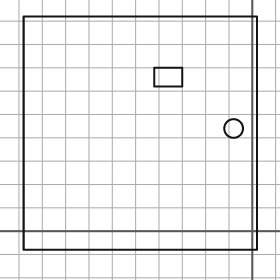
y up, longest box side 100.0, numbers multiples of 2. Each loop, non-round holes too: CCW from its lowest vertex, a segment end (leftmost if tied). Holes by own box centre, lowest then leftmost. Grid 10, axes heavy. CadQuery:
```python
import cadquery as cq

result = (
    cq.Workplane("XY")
    .moveTo(-98.0, -8.0)
    .lineTo(2.0, -8.0)
    .lineTo(2.0, 92.0)
    .lineTo(-98.0, 92.0)
    .close()
    .moveTo(-8.0, 44.0)
    .circle(4.0)
    .moveTo(-42.0, 62.0)
    .lineTo(-30.0, 62.0)
    .lineTo(-30.0, 70.0)
    .lineTo(-42.0, 70.0)
    .close()
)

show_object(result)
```